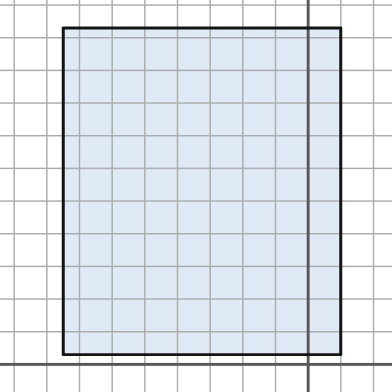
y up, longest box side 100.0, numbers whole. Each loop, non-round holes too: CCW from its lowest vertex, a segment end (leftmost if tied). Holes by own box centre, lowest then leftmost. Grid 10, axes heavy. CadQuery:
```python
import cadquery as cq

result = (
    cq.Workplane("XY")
    .moveTo(-75.0, 3.0)
    .lineTo(10.0, 3.0)
    .lineTo(10.0, 103.0)
    .lineTo(-75.0, 103.0)
    .close()
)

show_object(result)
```